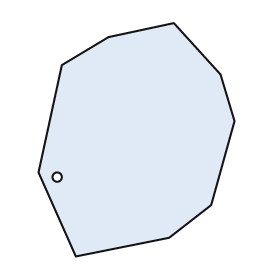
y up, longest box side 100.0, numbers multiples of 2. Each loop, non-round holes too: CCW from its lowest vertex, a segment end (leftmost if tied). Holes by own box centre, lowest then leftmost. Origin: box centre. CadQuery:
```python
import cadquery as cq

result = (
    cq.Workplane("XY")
    .moveTo(-26.0, -50.0)
    .lineTo(14.0, -42.0)
    .lineTo(32.0, -28.0)
    .lineTo(42.0, 8.0)
    .lineTo(36.0, 28.0)
    .lineTo(16.0, 50.0)
    .lineTo(-12.0, 44.0)
    .lineTo(-32.0, 32.0)
    .lineTo(-42.0, -14.0)
    .close()
    .moveTo(-34.0, -16.0)
    .circle(2.0)
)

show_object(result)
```